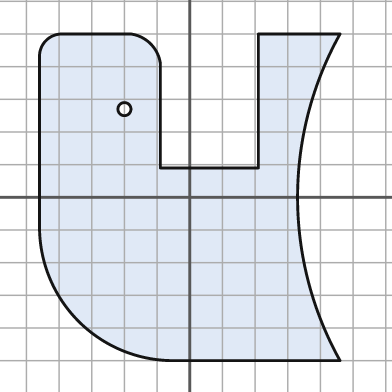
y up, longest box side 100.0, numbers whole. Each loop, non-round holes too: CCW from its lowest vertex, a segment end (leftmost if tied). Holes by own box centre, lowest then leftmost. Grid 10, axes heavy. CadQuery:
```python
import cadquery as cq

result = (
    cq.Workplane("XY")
    .moveTo(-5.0, -50.0)
    .lineTo(46.0, -50.0)
    .threePointArc((33.0, 0.0), (46.0, 50.0))
    .lineTo(21.0, 50.0)
    .lineTo(21.0, 9.0)
    .lineTo(-9.0, 9.0)
    .lineTo(-9.0, 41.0)
    .threePointArc((-12.0, 47.0), (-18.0, 50.0))
    .lineTo(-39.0, 50.0)
    .threePointArc((-44.0, 48.0), (-46.0, 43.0))
    .lineTo(-46.0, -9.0)
    .threePointArc((-34.0, -38.0), (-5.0, -50.0))
    .close()
    .moveTo(-20.0, 27.0)
    .circle(2.0)
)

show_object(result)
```